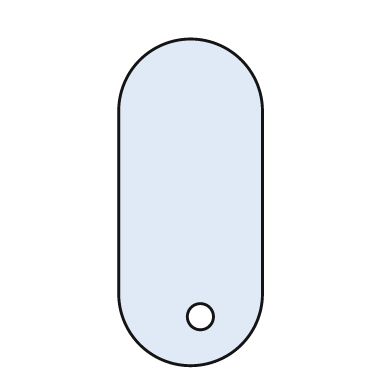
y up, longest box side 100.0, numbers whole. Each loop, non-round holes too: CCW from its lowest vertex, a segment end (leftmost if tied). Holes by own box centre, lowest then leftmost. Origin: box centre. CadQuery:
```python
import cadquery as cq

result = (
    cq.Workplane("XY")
    .moveTo(-22.0, -28.0)
    .threePointArc((0.0, -50.0), (22.0, -28.0))
    .lineTo(22.0, 28.0)
    .threePointArc((0.0, 50.0), (-22.0, 28.0))
    .close()
    .moveTo(3.0, -35.0)
    .circle(4.0)
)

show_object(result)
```